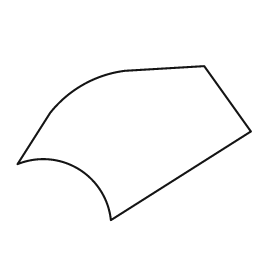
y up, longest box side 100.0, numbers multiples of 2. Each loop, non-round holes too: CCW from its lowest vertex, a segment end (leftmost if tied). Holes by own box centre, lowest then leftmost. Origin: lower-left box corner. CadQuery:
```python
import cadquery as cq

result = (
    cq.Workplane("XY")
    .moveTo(40.0, 0.0)
    .lineTo(100.0, 38.0)
    .lineTo(80.0, 66.0)
    .lineTo(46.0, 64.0)
    .threePointArc((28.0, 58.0), (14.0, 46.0))
    .lineTo(0.0, 24.0)
    .threePointArc((26.0, 22.0), (40.0, 0.0))
    .close()
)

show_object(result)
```